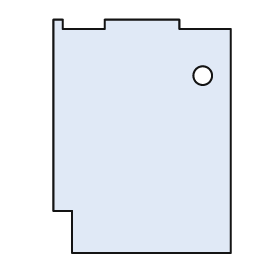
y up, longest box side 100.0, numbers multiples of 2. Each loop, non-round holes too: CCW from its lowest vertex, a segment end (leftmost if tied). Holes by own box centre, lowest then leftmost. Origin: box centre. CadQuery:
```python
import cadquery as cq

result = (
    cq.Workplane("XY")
    .moveTo(-30.0, -50.0)
    .lineTo(38.0, -50.0)
    .lineTo(38.0, 46.0)
    .lineTo(16.0, 46.0)
    .lineTo(16.0, 50.0)
    .lineTo(-16.0, 50.0)
    .lineTo(-16.0, 46.0)
    .lineTo(-34.0, 46.0)
    .lineTo(-34.0, 50.0)
    .lineTo(-38.0, 50.0)
    .lineTo(-38.0, -32.0)
    .lineTo(-30.0, -32.0)
    .close()
    .moveTo(26.0, 26.0)
    .circle(4.0)
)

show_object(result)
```